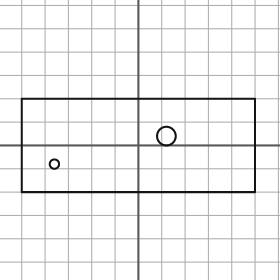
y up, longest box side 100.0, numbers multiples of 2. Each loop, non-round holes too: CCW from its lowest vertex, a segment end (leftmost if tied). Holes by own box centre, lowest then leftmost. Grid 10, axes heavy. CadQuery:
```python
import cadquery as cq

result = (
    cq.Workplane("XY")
    .moveTo(-50.0, -20.0)
    .lineTo(50.0, -20.0)
    .lineTo(50.0, 20.0)
    .lineTo(-50.0, 20.0)
    .close()
    .moveTo(-36.0, -8.0)
    .circle(2.0)
    .moveTo(12.0, 4.0)
    .circle(4.0)
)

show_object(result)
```